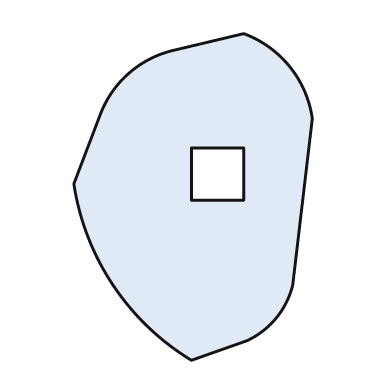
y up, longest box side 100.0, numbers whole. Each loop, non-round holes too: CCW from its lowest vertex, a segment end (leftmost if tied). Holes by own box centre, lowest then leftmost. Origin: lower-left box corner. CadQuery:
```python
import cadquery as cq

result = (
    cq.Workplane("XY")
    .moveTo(36.0, 0.0)
    .lineTo(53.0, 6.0)
    .threePointArc((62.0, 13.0), (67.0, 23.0))
    .lineTo(73.0, 74.0)
    .threePointArc((66.0, 90.0), (52.0, 100.0))
    .lineTo(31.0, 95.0)
    .threePointArc((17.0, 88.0), (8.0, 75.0))
    .lineTo(0.0, 54.0)
    .threePointArc((12.0, 23.0), (36.0, 0.0))
    .close()
    .moveTo(36.0, 49.0)
    .lineTo(52.0, 49.0)
    .lineTo(52.0, 65.0)
    .lineTo(36.0, 65.0)
    .close()
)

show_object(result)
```